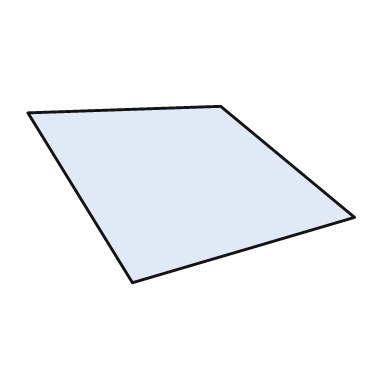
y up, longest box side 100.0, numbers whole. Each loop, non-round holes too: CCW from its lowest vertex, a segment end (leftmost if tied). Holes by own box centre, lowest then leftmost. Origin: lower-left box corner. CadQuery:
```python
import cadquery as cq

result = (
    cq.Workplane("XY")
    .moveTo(32.0, 0.0)
    .lineTo(100.0, 20.0)
    .lineTo(59.0, 54.0)
    .lineTo(0.0, 52.0)
    .close()
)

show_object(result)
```